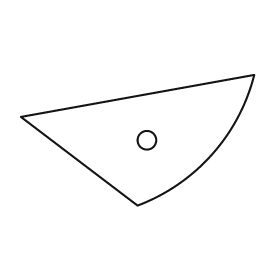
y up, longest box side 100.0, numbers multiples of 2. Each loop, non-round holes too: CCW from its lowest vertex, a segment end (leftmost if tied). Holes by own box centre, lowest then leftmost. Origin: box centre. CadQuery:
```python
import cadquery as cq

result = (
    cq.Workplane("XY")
    .moveTo(0.0, -28.0)
    .threePointArc((32.0, -6.0), (50.0, 28.0))
    .lineTo(-50.0, 10.0)
    .close()
    .moveTo(4.0, 0.0)
    .circle(4.0)
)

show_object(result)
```